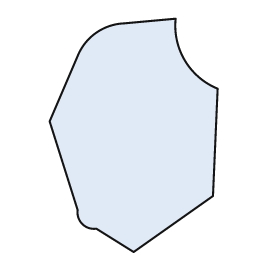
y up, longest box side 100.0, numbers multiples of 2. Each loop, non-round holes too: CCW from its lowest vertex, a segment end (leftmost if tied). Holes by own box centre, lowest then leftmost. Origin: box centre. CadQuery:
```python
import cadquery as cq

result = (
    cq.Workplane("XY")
    .moveTo(0.0, -50.0)
    .lineTo(34.0, -26.0)
    .lineTo(36.0, 20.0)
    .threePointArc((22.0, 32.0), (18.0, 50.0))
    .lineTo(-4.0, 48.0)
    .threePointArc((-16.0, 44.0), (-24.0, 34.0))
    .lineTo(-36.0, 6.0)
    .lineTo(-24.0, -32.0)
    .threePointArc((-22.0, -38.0), (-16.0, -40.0))
    .close()
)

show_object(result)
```